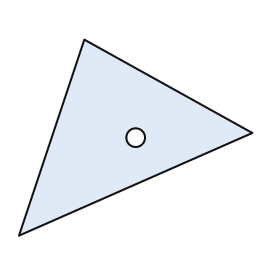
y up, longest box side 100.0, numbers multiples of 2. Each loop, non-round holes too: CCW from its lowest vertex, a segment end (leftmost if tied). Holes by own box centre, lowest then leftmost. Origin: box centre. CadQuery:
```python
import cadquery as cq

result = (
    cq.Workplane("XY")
    .moveTo(-50.0, -42.0)
    .lineTo(50.0, 2.0)
    .lineTo(-22.0, 42.0)
    .close()
    .moveTo(0.0, 0.0)
    .circle(4.0)
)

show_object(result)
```